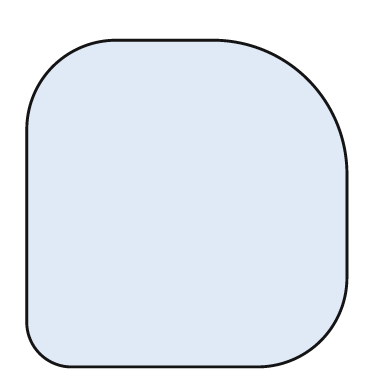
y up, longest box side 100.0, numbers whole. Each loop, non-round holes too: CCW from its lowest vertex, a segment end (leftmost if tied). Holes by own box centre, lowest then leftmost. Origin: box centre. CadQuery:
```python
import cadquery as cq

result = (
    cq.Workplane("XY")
    .moveTo(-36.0, -50.0)
    .lineTo(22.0, -50.0)
    .threePointArc((41.0, -42.0), (49.0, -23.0))
    .lineTo(49.0, 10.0)
    .threePointArc((37.0, 38.0), (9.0, 50.0))
    .lineTo(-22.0, 50.0)
    .threePointArc((-41.0, 42.0), (-49.0, 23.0))
    .lineTo(-49.0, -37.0)
    .threePointArc((-45.0, -46.0), (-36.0, -50.0))
    .close()
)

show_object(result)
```